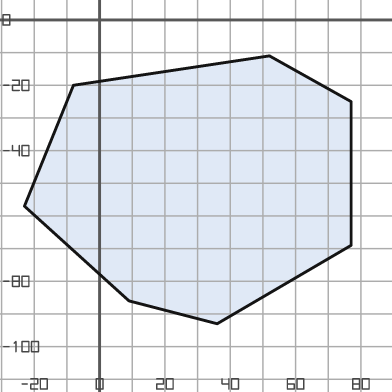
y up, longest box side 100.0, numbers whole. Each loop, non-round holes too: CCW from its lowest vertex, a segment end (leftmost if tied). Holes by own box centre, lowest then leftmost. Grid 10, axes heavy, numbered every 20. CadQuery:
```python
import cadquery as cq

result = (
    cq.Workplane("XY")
    .moveTo(36.0, -93.0)
    .lineTo(77.0, -69.0)
    .lineTo(77.0, -25.0)
    .lineTo(52.0, -11.0)
    .lineTo(-8.0, -20.0)
    .lineTo(-23.0, -57.0)
    .lineTo(9.0, -86.0)
    .close()
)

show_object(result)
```